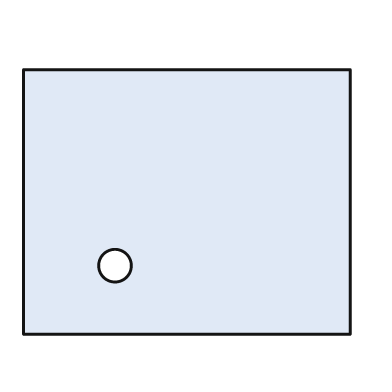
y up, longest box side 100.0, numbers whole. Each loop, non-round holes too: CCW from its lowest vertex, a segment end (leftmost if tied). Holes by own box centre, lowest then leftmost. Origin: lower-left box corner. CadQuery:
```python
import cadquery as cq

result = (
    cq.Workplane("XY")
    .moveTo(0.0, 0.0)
    .lineTo(100.0, 0.0)
    .lineTo(100.0, 81.0)
    .lineTo(0.0, 81.0)
    .close()
    .moveTo(28.0, 21.0)
    .circle(5.0)
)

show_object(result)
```